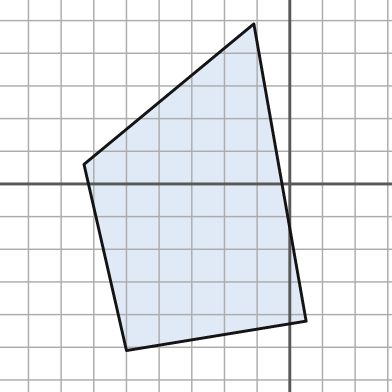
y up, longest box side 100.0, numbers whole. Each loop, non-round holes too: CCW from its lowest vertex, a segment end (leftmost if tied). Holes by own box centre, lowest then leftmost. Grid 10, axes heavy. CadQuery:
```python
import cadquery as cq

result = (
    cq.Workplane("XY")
    .moveTo(-50.0, -51.0)
    .lineTo(5.0, -42.0)
    .lineTo(-11.0, 49.0)
    .lineTo(-63.0, 6.0)
    .close()
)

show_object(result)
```